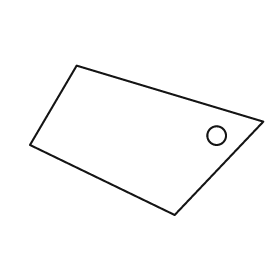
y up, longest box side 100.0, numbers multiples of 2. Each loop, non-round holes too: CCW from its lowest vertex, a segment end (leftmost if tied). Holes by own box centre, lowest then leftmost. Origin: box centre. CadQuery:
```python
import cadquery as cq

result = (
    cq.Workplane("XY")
    .moveTo(12.0, -32.0)
    .lineTo(50.0, 8.0)
    .lineTo(-30.0, 32.0)
    .lineTo(-50.0, -2.0)
    .close()
    .moveTo(30.0, 2.0)
    .circle(4.0)
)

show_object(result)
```